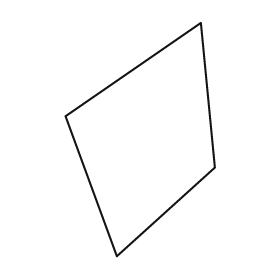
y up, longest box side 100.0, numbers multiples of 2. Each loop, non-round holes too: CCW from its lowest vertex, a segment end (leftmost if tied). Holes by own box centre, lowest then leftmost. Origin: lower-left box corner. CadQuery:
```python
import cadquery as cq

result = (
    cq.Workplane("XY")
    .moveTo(22.0, 0.0)
    .lineTo(64.0, 38.0)
    .lineTo(58.0, 100.0)
    .lineTo(0.0, 60.0)
    .close()
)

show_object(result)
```